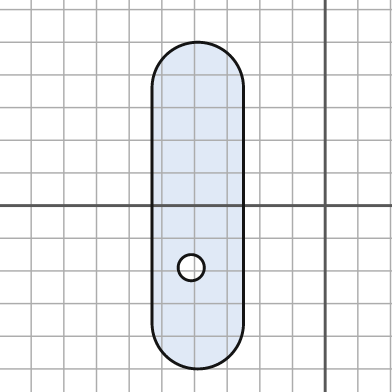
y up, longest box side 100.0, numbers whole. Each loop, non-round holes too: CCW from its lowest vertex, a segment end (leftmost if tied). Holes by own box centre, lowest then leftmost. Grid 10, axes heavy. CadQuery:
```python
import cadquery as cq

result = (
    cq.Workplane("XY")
    .moveTo(-53.0, -36.0)
    .threePointArc((-39.0, -50.0), (-25.0, -36.0))
    .lineTo(-25.0, 36.0)
    .threePointArc((-39.0, 50.0), (-53.0, 36.0))
    .close()
    .moveTo(-41.0, -19.0)
    .circle(4.0)
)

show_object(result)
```